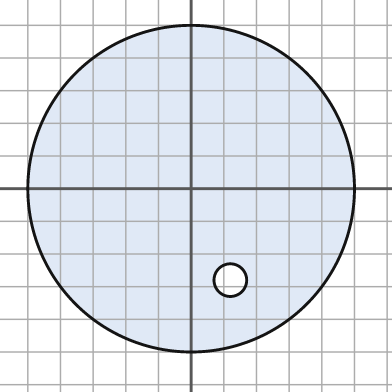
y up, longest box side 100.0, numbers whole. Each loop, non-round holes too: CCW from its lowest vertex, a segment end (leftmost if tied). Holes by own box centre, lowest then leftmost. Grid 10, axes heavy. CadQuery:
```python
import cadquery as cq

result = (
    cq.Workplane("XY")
    .moveTo(0.0, 0.0)
    .circle(50.0)
    .moveTo(12.0, -28.0)
    .circle(5.0)
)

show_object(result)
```